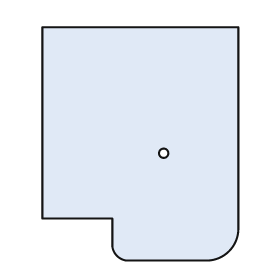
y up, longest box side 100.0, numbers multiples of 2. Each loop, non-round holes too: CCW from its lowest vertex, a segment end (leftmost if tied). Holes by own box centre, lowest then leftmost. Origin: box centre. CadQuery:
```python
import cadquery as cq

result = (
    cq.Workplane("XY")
    .moveTo(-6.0, -50.0)
    .lineTo(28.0, -50.0)
    .threePointArc((38.0, -46.0), (42.0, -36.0))
    .lineTo(42.0, 50.0)
    .lineTo(-42.0, 50.0)
    .lineTo(-42.0, -32.0)
    .lineTo(-12.0, -32.0)
    .lineTo(-12.0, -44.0)
    .threePointArc((-10.0, -48.0), (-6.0, -50.0))
    .close()
    .moveTo(10.0, -4.0)
    .circle(2.0)
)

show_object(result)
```